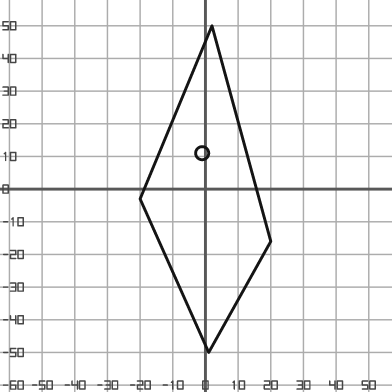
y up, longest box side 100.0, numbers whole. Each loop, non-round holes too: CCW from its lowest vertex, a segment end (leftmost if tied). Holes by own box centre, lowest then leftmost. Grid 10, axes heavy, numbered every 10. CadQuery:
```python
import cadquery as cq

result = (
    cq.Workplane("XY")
    .moveTo(1.0, -50.0)
    .lineTo(20.0, -16.0)
    .lineTo(2.0, 50.0)
    .lineTo(-20.0, -3.0)
    .close()
    .moveTo(-1.0, 11.0)
    .circle(2.0)
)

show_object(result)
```